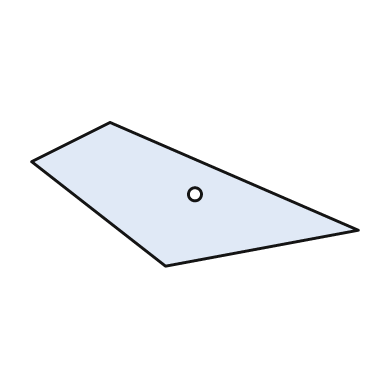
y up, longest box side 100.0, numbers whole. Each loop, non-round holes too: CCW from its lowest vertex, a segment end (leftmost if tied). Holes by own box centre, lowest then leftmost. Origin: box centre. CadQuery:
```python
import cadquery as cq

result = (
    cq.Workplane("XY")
    .moveTo(-9.0, -22.0)
    .lineTo(50.0, -11.0)
    .lineTo(-26.0, 22.0)
    .lineTo(-50.0, 10.0)
    .close()
    .moveTo(0.0, 0.0)
    .circle(2.0)
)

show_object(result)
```